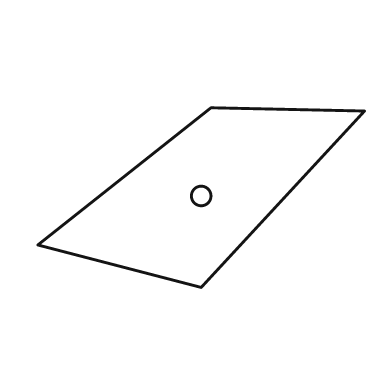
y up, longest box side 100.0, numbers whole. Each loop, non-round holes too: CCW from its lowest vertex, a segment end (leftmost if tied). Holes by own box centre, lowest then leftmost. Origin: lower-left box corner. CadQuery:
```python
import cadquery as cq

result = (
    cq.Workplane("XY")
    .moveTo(50.0, 0.0)
    .lineTo(100.0, 54.0)
    .lineTo(53.0, 55.0)
    .lineTo(0.0, 13.0)
    .close()
    .moveTo(50.0, 28.0)
    .circle(3.0)
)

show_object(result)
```